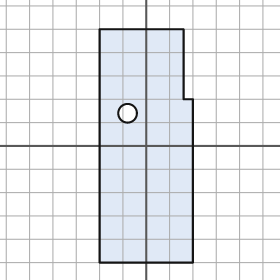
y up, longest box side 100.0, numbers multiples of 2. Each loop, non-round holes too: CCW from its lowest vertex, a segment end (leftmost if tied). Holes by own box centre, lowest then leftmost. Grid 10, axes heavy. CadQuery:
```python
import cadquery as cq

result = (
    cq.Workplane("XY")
    .moveTo(-20.0, -50.0)
    .lineTo(20.0, -50.0)
    .lineTo(20.0, 20.0)
    .lineTo(16.0, 20.0)
    .lineTo(16.0, 50.0)
    .lineTo(-20.0, 50.0)
    .close()
    .moveTo(-8.0, 14.0)
    .circle(4.0)
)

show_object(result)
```